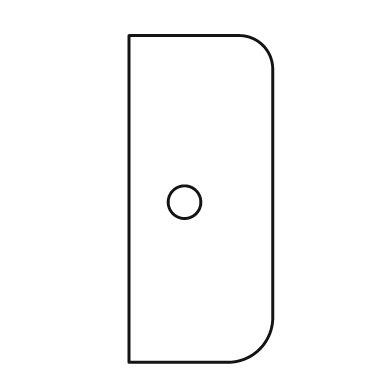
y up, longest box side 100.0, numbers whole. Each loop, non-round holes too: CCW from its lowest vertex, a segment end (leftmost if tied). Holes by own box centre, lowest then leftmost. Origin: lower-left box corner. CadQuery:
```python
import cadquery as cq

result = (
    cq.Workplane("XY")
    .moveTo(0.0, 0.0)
    .lineTo(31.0, 0.0)
    .threePointArc((40.0, 4.0), (44.0, 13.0))
    .lineTo(44.0, 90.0)
    .threePointArc((41.0, 97.0), (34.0, 100.0))
    .lineTo(0.0, 100.0)
    .close()
    .moveTo(17.0, 49.0)
    .circle(5.0)
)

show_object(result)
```